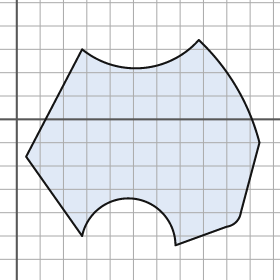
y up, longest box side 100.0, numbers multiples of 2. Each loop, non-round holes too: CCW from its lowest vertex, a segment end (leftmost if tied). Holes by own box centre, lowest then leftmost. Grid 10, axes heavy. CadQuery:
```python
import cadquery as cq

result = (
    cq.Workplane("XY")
    .moveTo(68.0, -54.0)
    .lineTo(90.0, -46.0)
    .threePointArc((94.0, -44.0), (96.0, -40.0))
    .lineTo(104.0, -10.0)
    .threePointArc((94.0, 14.0), (78.0, 34.0))
    .threePointArc((54.0, 22.0), (28.0, 30.0))
    .lineTo(4.0, -16.0)
    .lineTo(28.0, -50.0)
    .threePointArc((50.0, -34.0), (68.0, -54.0))
    .close()
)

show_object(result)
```